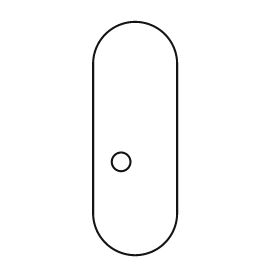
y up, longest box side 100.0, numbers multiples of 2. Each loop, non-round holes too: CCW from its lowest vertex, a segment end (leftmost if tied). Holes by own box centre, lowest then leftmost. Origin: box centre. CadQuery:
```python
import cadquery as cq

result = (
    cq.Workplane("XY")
    .moveTo(-18.0, -32.0)
    .threePointArc((0.0, -50.0), (18.0, -32.0))
    .lineTo(18.0, 32.0)
    .threePointArc((0.0, 50.0), (-18.0, 32.0))
    .close()
    .moveTo(-6.0, -10.0)
    .circle(4.0)
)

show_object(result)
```